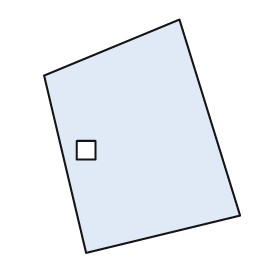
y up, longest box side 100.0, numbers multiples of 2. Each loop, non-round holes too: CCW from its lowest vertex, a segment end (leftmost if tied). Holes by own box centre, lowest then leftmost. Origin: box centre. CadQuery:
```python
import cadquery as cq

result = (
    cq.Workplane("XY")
    .moveTo(-24.0, -50.0)
    .lineTo(42.0, -34.0)
    .lineTo(16.0, 50.0)
    .lineTo(-42.0, 26.0)
    .close()
    .moveTo(-28.0, -10.0)
    .lineTo(-20.0, -10.0)
    .lineTo(-20.0, -2.0)
    .lineTo(-28.0, -2.0)
    .close()
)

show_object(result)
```